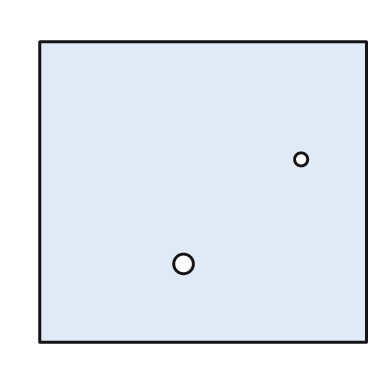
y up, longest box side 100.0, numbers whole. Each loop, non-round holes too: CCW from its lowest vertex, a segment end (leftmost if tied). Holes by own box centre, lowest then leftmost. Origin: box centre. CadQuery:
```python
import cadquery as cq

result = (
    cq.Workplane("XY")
    .moveTo(-50.0, -46.0)
    .lineTo(50.0, -46.0)
    .lineTo(50.0, 46.0)
    .lineTo(-50.0, 46.0)
    .close()
    .moveTo(-6.0, -22.0)
    .circle(3.0)
    .moveTo(30.0, 10.0)
    .circle(2.0)
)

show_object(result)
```